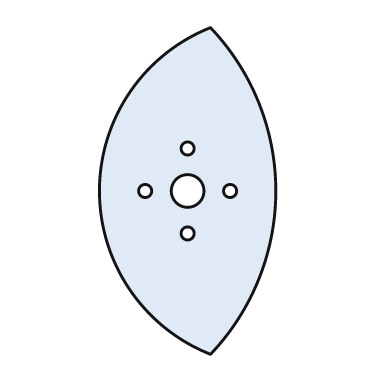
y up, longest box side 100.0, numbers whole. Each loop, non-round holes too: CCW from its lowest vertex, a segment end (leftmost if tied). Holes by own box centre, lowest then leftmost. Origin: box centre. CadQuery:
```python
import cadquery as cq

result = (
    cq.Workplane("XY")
    .moveTo(7.0, -50.0)
    .threePointArc((27.0, 0.0), (7.0, 50.0))
    .threePointArc((-27.0, 0.0), (7.0, -50.0))
    .close()
    .moveTo(0.0, -13.0)
    .circle(2.0)
    .moveTo(-13.0, 0.0)
    .circle(2.0)
    .moveTo(0.0, 0.0)
    .circle(5.0)
    .moveTo(13.0, 0.0)
    .circle(2.0)
    .moveTo(0.0, 13.0)
    .circle(2.0)
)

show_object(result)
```